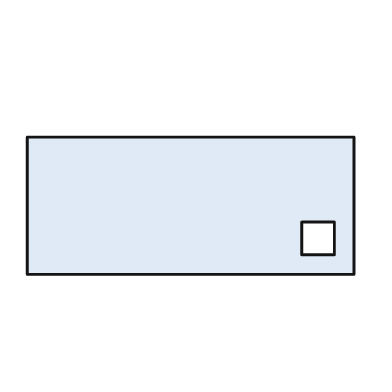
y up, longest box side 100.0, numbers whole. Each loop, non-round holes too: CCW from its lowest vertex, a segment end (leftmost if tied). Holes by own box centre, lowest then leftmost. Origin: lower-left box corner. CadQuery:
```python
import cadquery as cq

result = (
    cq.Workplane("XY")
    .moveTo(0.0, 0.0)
    .lineTo(100.0, 0.0)
    .lineTo(100.0, 42.0)
    .lineTo(0.0, 42.0)
    .close()
    .moveTo(84.0, 6.0)
    .lineTo(94.0, 6.0)
    .lineTo(94.0, 16.0)
    .lineTo(84.0, 16.0)
    .close()
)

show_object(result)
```